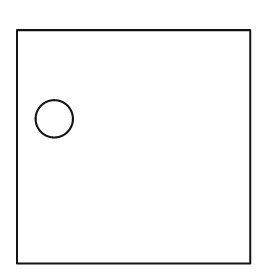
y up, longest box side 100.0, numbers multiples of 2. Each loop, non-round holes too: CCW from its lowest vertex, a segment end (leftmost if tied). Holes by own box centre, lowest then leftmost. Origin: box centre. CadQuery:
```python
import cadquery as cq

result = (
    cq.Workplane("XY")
    .moveTo(-50.0, -50.0)
    .lineTo(50.0, -50.0)
    .lineTo(50.0, 50.0)
    .lineTo(-50.0, 50.0)
    .close()
    .moveTo(-34.0, 12.0)
    .circle(8.0)
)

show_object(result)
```